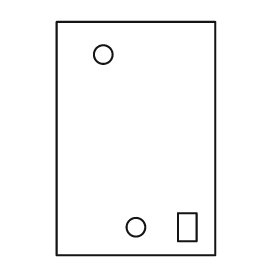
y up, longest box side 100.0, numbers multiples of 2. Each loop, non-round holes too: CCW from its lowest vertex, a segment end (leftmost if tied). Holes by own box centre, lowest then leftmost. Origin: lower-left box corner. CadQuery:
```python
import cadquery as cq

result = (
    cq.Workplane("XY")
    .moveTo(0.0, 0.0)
    .lineTo(68.0, 0.0)
    .lineTo(68.0, 100.0)
    .lineTo(0.0, 100.0)
    .close()
    .moveTo(34.0, 12.0)
    .circle(4.0)
    .moveTo(52.0, 6.0)
    .lineTo(60.0, 6.0)
    .lineTo(60.0, 18.0)
    .lineTo(52.0, 18.0)
    .close()
    .moveTo(20.0, 86.0)
    .circle(4.0)
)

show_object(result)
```